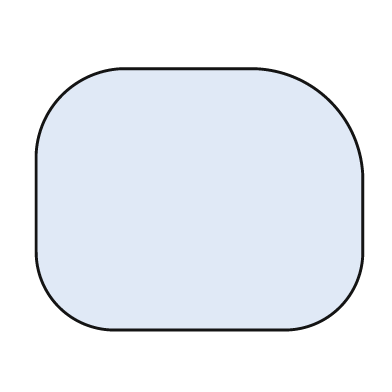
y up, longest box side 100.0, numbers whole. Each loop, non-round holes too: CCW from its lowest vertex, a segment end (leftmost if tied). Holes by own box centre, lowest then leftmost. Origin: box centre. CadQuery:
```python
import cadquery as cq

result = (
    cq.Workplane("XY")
    .moveTo(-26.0, -40.0)
    .lineTo(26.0, -40.0)
    .threePointArc((43.0, -33.0), (50.0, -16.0))
    .lineTo(50.0, 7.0)
    .threePointArc((40.0, 30.0), (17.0, 40.0))
    .lineTo(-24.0, 40.0)
    .threePointArc((-42.0, 32.0), (-50.0, 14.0))
    .lineTo(-50.0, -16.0)
    .threePointArc((-43.0, -33.0), (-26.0, -40.0))
    .close()
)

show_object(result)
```